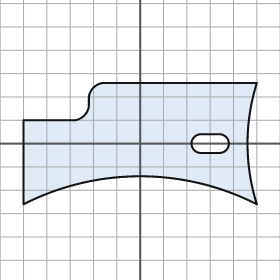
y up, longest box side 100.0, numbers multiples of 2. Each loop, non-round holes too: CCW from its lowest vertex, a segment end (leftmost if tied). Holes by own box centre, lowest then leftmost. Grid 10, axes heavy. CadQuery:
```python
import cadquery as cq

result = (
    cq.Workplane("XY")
    .moveTo(-50.0, -26.0)
    .threePointArc((0.0, -14.0), (50.0, -26.0))
    .threePointArc((46.0, 0.0), (50.0, 26.0))
    .lineTo(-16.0, 26.0)
    .threePointArc((-20.0, 24.0), (-22.0, 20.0))
    .lineTo(-22.0, 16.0)
    .threePointArc((-24.0, 12.0), (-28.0, 10.0))
    .lineTo(-50.0, 10.0)
    .close()
    .moveTo(26.0, -4.0)
    .lineTo(34.0, -4.0)
    .threePointArc((38.0, 0.0), (34.0, 4.0))
    .lineTo(26.0, 4.0)
    .threePointArc((22.0, 0.0), (26.0, -4.0))
    .close()
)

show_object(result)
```